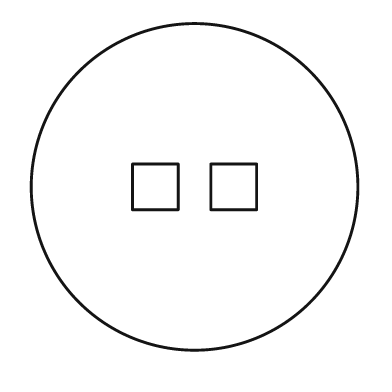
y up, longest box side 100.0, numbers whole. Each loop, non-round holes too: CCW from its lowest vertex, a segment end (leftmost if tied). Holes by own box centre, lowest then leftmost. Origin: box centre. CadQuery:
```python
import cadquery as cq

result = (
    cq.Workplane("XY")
    .moveTo(0.0, 0.0)
    .circle(50.0)
    .moveTo(-19.0, -7.0)
    .lineTo(-5.0, -7.0)
    .lineTo(-5.0, 7.0)
    .lineTo(-19.0, 7.0)
    .close()
    .moveTo(5.0, -7.0)
    .lineTo(19.0, -7.0)
    .lineTo(19.0, 7.0)
    .lineTo(5.0, 7.0)
    .close()
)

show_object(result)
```